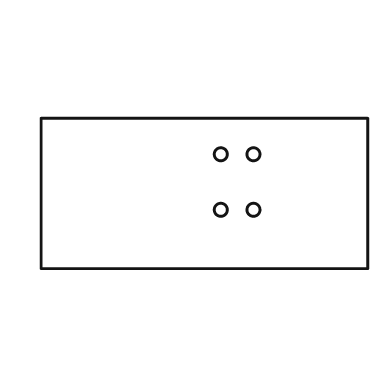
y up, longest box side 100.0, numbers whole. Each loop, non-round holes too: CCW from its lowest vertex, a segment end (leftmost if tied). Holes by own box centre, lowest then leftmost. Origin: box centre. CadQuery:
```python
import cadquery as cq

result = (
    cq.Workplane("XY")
    .moveTo(-50.0, -23.0)
    .lineTo(50.0, -23.0)
    .lineTo(50.0, 23.0)
    .lineTo(-50.0, 23.0)
    .close()
    .moveTo(5.0, -5.0)
    .circle(2.0)
    .moveTo(15.0, -5.0)
    .circle(2.0)
    .moveTo(5.0, 12.0)
    .circle(2.0)
    .moveTo(15.0, 12.0)
    .circle(2.0)
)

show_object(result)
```